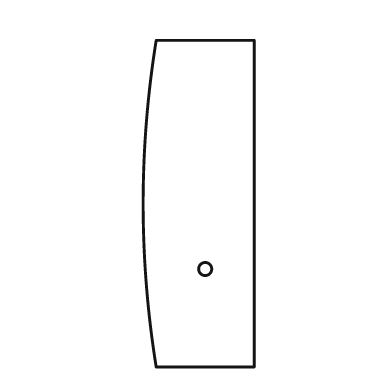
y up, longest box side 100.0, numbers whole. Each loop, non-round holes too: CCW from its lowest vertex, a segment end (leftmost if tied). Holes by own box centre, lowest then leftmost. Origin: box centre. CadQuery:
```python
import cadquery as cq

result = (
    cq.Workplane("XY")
    .moveTo(-13.0, -50.0)
    .lineTo(17.0, -50.0)
    .lineTo(17.0, 50.0)
    .lineTo(-13.0, 50.0)
    .threePointArc((-17.0, 0.0), (-13.0, -50.0))
    .close()
    .moveTo(2.0, -20.0)
    .circle(2.0)
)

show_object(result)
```